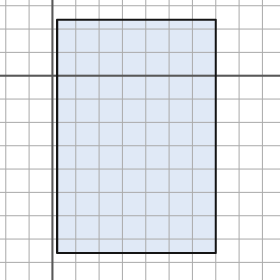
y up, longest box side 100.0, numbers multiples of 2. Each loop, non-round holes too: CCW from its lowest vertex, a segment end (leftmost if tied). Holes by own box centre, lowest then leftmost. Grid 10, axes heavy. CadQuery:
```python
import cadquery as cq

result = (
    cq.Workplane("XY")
    .moveTo(2.0, -76.0)
    .lineTo(70.0, -76.0)
    .lineTo(70.0, 24.0)
    .lineTo(2.0, 24.0)
    .close()
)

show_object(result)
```